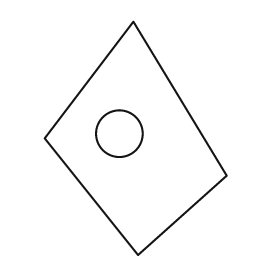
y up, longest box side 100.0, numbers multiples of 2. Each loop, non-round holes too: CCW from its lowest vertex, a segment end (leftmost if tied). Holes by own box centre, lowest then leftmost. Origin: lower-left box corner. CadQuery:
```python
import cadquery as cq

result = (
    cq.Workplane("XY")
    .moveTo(40.0, 0.0)
    .lineTo(78.0, 34.0)
    .lineTo(38.0, 100.0)
    .lineTo(0.0, 50.0)
    .close()
    .moveTo(32.0, 52.0)
    .circle(10.0)
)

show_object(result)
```